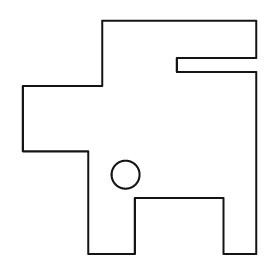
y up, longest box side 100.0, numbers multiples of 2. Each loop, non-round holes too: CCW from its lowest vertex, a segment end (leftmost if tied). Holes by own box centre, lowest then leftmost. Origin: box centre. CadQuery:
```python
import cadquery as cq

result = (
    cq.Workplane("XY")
    .moveTo(-22.0, -50.0)
    .lineTo(-2.0, -50.0)
    .lineTo(-2.0, -26.0)
    .lineTo(36.0, -26.0)
    .lineTo(36.0, -50.0)
    .lineTo(50.0, -50.0)
    .lineTo(50.0, 28.0)
    .lineTo(16.0, 28.0)
    .lineTo(16.0, 34.0)
    .lineTo(50.0, 34.0)
    .lineTo(50.0, 50.0)
    .lineTo(-16.0, 50.0)
    .lineTo(-16.0, 22.0)
    .lineTo(-50.0, 22.0)
    .lineTo(-50.0, -6.0)
    .lineTo(-22.0, -6.0)
    .close()
    .moveTo(-6.0, -16.0)
    .circle(6.0)
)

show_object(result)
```